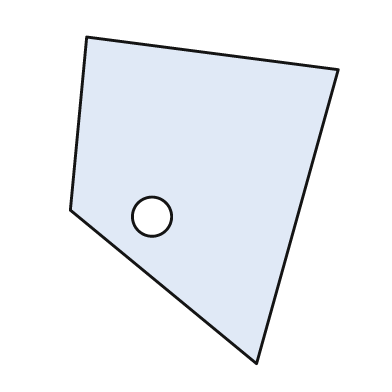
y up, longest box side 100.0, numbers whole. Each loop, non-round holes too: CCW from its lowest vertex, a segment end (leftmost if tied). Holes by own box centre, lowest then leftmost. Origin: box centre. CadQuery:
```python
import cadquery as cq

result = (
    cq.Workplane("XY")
    .moveTo(16.0, -50.0)
    .lineTo(41.0, 40.0)
    .lineTo(-36.0, 50.0)
    .lineTo(-41.0, -3.0)
    .close()
    .moveTo(-16.0, -5.0)
    .circle(6.0)
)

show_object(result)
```